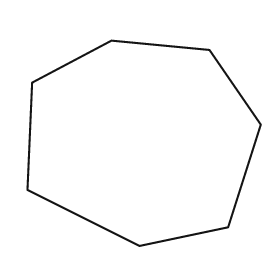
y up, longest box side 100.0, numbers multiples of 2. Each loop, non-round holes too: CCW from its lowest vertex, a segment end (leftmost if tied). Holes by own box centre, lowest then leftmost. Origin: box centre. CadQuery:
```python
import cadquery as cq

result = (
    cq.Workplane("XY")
    .moveTo(-2.0, -44.0)
    .lineTo(36.0, -36.0)
    .lineTo(50.0, 8.0)
    .lineTo(28.0, 40.0)
    .lineTo(-14.0, 44.0)
    .lineTo(-48.0, 26.0)
    .lineTo(-50.0, -20.0)
    .close()
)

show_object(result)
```